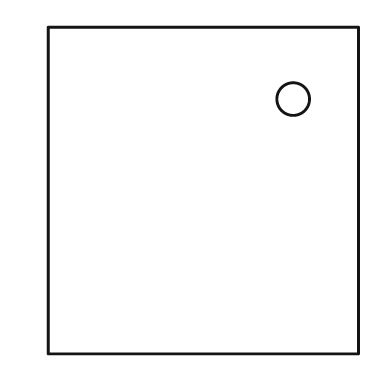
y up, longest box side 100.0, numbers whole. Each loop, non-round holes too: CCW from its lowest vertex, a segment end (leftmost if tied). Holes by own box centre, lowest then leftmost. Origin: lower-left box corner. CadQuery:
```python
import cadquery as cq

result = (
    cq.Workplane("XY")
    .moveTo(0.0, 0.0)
    .lineTo(95.0, 0.0)
    .lineTo(95.0, 100.0)
    .lineTo(0.0, 100.0)
    .close()
    .moveTo(75.0, 78.0)
    .circle(5.0)
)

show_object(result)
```